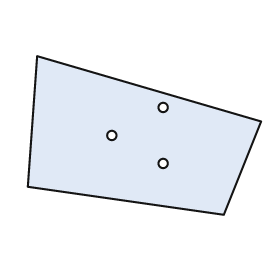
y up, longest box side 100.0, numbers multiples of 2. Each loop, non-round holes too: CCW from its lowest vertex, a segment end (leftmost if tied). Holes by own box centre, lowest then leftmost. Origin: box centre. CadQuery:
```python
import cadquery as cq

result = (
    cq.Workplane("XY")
    .moveTo(34.0, -34.0)
    .lineTo(50.0, 6.0)
    .lineTo(-46.0, 34.0)
    .lineTo(-50.0, -22.0)
    .close()
    .moveTo(8.0, -12.0)
    .circle(2.0)
    .moveTo(-14.0, 0.0)
    .circle(2.0)
    .moveTo(8.0, 12.0)
    .circle(2.0)
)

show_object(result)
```